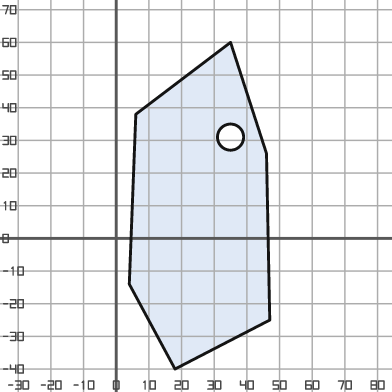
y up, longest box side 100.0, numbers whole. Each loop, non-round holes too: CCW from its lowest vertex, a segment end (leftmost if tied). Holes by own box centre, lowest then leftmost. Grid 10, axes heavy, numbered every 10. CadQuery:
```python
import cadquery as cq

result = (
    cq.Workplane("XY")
    .moveTo(18.0, -40.0)
    .lineTo(47.0, -25.0)
    .lineTo(46.0, 26.0)
    .lineTo(35.0, 60.0)
    .lineTo(6.0, 38.0)
    .lineTo(4.0, -14.0)
    .close()
    .moveTo(35.0, 31.0)
    .circle(4.0)
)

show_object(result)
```